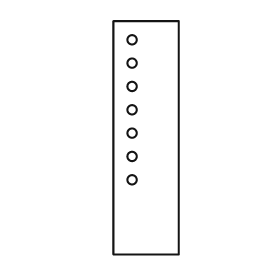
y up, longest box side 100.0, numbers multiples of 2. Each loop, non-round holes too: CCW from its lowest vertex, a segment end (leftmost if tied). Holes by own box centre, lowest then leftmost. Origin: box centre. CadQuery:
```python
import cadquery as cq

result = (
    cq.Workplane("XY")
    .moveTo(-14.0, -50.0)
    .lineTo(14.0, -50.0)
    .lineTo(14.0, 50.0)
    .lineTo(-14.0, 50.0)
    .close()
    .moveTo(-6.0, -18.0)
    .circle(2.0)
    .moveTo(-6.0, -8.0)
    .circle(2.0)
    .moveTo(-6.0, 2.0)
    .circle(2.0)
    .moveTo(-6.0, 12.0)
    .circle(2.0)
    .moveTo(-6.0, 22.0)
    .circle(2.0)
    .moveTo(-6.0, 32.0)
    .circle(2.0)
    .moveTo(-6.0, 42.0)
    .circle(2.0)
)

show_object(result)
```